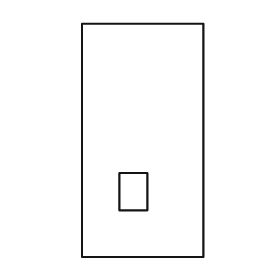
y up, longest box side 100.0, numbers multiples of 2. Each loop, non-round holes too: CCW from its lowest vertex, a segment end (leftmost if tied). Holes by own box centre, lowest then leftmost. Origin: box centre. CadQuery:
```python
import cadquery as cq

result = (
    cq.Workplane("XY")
    .moveTo(-26.0, -50.0)
    .lineTo(26.0, -50.0)
    .lineTo(26.0, 50.0)
    .lineTo(-26.0, 50.0)
    .close()
    .moveTo(-10.0, -30.0)
    .lineTo(2.0, -30.0)
    .lineTo(2.0, -14.0)
    .lineTo(-10.0, -14.0)
    .close()
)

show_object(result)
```